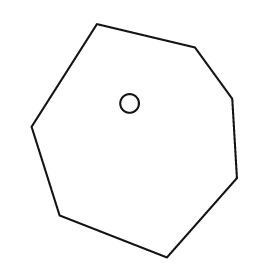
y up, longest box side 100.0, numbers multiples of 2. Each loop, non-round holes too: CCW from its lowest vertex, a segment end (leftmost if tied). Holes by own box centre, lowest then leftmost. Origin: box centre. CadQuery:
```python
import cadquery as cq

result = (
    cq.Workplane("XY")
    .moveTo(14.0, -50.0)
    .lineTo(44.0, -16.0)
    .lineTo(42.0, 18.0)
    .lineTo(26.0, 40.0)
    .lineTo(-16.0, 50.0)
    .lineTo(-44.0, 6.0)
    .lineTo(-32.0, -32.0)
    .close()
    .moveTo(-2.0, 16.0)
    .circle(4.0)
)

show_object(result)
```